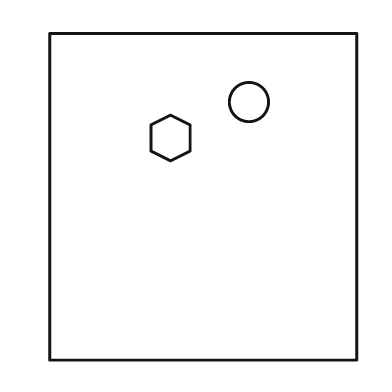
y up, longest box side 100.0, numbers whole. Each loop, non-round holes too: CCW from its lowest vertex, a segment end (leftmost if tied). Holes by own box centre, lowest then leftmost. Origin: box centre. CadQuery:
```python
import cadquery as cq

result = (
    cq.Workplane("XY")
    .moveTo(-47.0, -50.0)
    .lineTo(47.0, -50.0)
    .lineTo(47.0, 50.0)
    .lineTo(-47.0, 50.0)
    .close()
    .moveTo(-10.0, 11.0)
    .lineTo(-4.0, 14.0)
    .lineTo(-4.0, 22.0)
    .lineTo(-10.0, 25.0)
    .lineTo(-16.0, 22.0)
    .lineTo(-16.0, 14.0)
    .close()
    .moveTo(14.0, 29.0)
    .circle(6.0)
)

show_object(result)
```